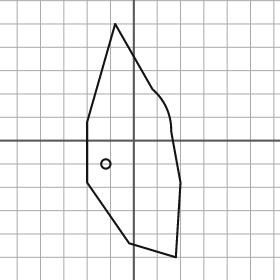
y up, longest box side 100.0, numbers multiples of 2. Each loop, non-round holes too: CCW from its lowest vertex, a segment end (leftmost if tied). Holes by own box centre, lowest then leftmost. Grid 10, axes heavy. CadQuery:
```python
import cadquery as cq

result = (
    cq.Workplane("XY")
    .moveTo(18.0, -50.0)
    .lineTo(20.0, -18.0)
    .lineTo(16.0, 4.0)
    .threePointArc((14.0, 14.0), (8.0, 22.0))
    .lineTo(-8.0, 50.0)
    .lineTo(-20.0, 8.0)
    .lineTo(-20.0, -18.0)
    .lineTo(-2.0, -44.0)
    .close()
    .moveTo(-12.0, -10.0)
    .circle(2.0)
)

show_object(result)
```